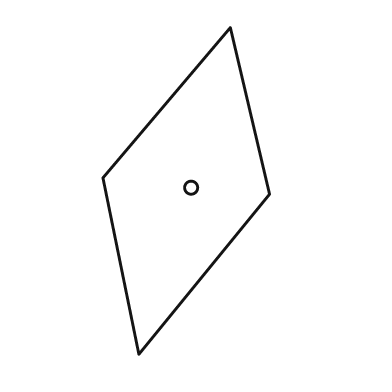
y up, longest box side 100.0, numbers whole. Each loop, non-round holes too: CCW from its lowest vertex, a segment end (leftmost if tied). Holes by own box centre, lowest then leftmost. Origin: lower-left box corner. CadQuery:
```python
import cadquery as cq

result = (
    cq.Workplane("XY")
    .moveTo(11.0, 0.0)
    .lineTo(51.0, 49.0)
    .lineTo(39.0, 100.0)
    .lineTo(0.0, 54.0)
    .close()
    .moveTo(27.0, 51.0)
    .circle(2.0)
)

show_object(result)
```